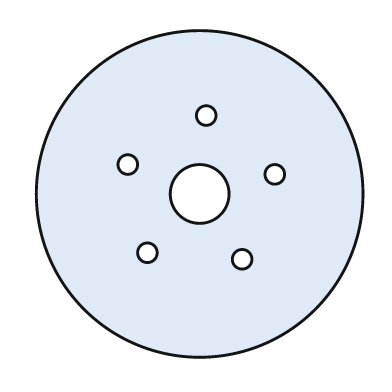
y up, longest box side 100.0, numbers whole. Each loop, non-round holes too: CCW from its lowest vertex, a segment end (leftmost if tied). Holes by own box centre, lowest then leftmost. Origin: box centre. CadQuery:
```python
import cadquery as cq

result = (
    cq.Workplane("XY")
    .moveTo(0.0, 0.0)
    .circle(50.0)
    .moveTo(13.0, -20.0)
    .circle(3.0)
    .moveTo(-16.0, -18.0)
    .circle(3.0)
    .moveTo(0.0, 0.0)
    .circle(9.0)
    .moveTo(23.0, 6.0)
    .circle(3.0)
    .moveTo(-22.0, 9.0)
    .circle(3.0)
    .moveTo(2.0, 24.0)
    .circle(3.0)
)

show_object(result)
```